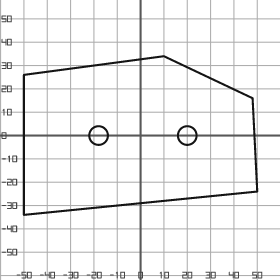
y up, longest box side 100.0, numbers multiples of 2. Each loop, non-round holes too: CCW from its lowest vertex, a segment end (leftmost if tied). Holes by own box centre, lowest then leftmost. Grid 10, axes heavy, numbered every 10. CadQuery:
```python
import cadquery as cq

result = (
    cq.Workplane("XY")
    .moveTo(-50.0, -34.0)
    .lineTo(50.0, -24.0)
    .lineTo(48.0, 16.0)
    .lineTo(10.0, 34.0)
    .lineTo(-50.0, 26.0)
    .close()
    .moveTo(-18.0, 0.0)
    .circle(4.0)
    .moveTo(20.0, 0.0)
    .circle(4.0)
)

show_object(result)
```